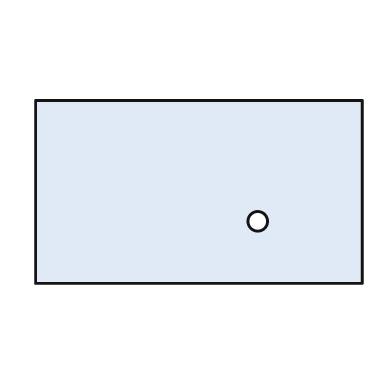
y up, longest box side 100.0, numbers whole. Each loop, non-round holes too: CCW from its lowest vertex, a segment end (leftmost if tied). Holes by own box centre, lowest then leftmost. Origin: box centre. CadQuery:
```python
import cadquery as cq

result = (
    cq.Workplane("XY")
    .moveTo(-50.0, -28.0)
    .lineTo(50.0, -28.0)
    .lineTo(50.0, 28.0)
    .lineTo(-50.0, 28.0)
    .close()
    .moveTo(18.0, -9.0)
    .circle(3.0)
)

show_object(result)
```